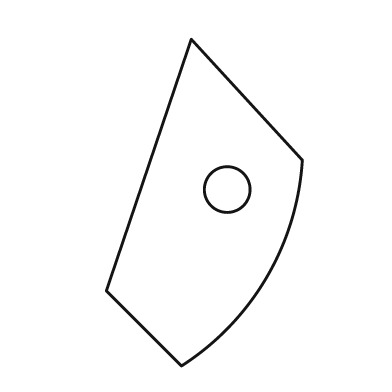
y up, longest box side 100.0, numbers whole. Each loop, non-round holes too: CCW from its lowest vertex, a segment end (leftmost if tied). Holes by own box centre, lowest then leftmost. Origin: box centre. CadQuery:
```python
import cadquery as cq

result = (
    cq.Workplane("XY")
    .moveTo(-7.0, -50.0)
    .threePointArc((19.0, -23.0), (30.0, 13.0))
    .lineTo(-4.0, 50.0)
    .lineTo(-30.0, -27.0)
    .close()
    .moveTo(7.0, 4.0)
    .circle(7.0)
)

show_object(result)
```